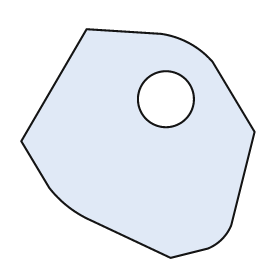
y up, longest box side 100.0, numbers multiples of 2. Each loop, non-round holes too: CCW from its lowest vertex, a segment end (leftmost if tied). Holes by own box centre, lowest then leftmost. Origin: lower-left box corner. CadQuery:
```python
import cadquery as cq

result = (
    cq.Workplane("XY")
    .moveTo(64.0, 0.0)
    .lineTo(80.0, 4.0)
    .threePointArc((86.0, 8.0), (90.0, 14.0))
    .lineTo(100.0, 54.0)
    .lineTo(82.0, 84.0)
    .threePointArc((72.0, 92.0), (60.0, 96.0))
    .lineTo(28.0, 98.0)
    .lineTo(0.0, 50.0)
    .lineTo(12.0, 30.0)
    .threePointArc((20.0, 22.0), (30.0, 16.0))
    .close()
    .moveTo(62.0, 68.0)
    .circle(12.0)
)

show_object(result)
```